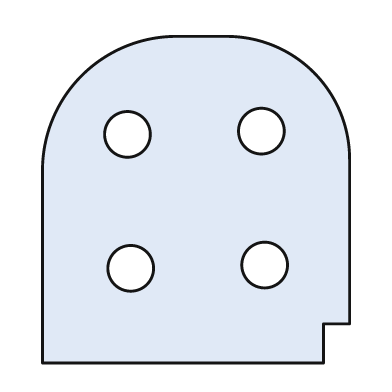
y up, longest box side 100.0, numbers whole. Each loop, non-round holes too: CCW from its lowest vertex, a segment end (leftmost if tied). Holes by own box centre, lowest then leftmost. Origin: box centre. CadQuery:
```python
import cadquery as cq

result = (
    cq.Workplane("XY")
    .moveTo(-47.0, -50.0)
    .lineTo(39.0, -50.0)
    .lineTo(39.0, -38.0)
    .lineTo(47.0, -38.0)
    .lineTo(47.0, 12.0)
    .threePointArc((36.0, 39.0), (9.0, 50.0))
    .lineTo(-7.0, 50.0)
    .threePointArc((-35.0, 38.0), (-47.0, 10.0))
    .close()
    .moveTo(-20.0, -21.0)
    .circle(7.0)
    .moveTo(21.0, -20.0)
    .circle(7.0)
    .moveTo(-21.0, 20.0)
    .circle(7.0)
    .moveTo(20.0, 21.0)
    .circle(7.0)
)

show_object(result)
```